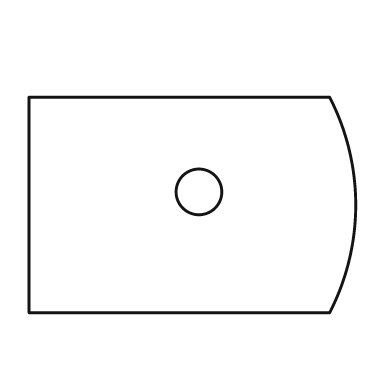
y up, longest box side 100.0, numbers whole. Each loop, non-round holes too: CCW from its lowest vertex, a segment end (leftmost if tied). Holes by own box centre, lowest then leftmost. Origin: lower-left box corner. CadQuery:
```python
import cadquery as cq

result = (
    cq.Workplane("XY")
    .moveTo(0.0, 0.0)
    .lineTo(92.0, 0.0)
    .threePointArc((100.0, 33.0), (92.0, 66.0))
    .lineTo(0.0, 66.0)
    .close()
    .moveTo(52.0, 37.0)
    .circle(7.0)
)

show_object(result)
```